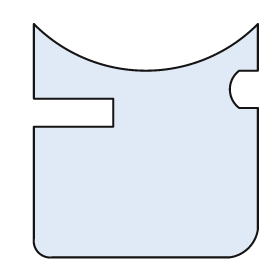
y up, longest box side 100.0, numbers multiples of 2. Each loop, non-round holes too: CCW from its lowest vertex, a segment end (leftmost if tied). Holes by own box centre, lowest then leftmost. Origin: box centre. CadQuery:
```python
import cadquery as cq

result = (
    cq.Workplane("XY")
    .moveTo(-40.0, -50.0)
    .lineTo(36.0, -50.0)
    .threePointArc((44.0, -46.0), (48.0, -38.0))
    .lineTo(48.0, 14.0)
    .lineTo(40.0, 14.0)
    .threePointArc((36.0, 22.0), (40.0, 30.0))
    .lineTo(48.0, 30.0)
    .lineTo(48.0, 50.0)
    .threePointArc((0.0, 30.0), (-48.0, 50.0))
    .lineTo(-48.0, 18.0)
    .lineTo(-14.0, 18.0)
    .lineTo(-14.0, 6.0)
    .lineTo(-48.0, 6.0)
    .lineTo(-48.0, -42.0)
    .threePointArc((-46.0, -48.0), (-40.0, -50.0))
    .close()
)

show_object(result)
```